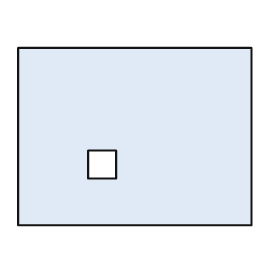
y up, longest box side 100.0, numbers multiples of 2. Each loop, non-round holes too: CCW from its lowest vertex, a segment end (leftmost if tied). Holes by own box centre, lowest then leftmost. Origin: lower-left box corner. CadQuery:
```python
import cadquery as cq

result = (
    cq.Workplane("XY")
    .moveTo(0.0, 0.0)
    .lineTo(100.0, 0.0)
    .lineTo(100.0, 76.0)
    .lineTo(0.0, 76.0)
    .close()
    .moveTo(30.0, 20.0)
    .lineTo(42.0, 20.0)
    .lineTo(42.0, 32.0)
    .lineTo(30.0, 32.0)
    .close()
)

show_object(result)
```